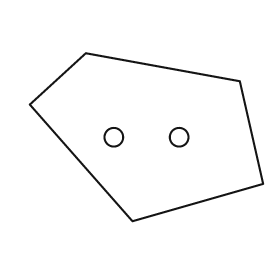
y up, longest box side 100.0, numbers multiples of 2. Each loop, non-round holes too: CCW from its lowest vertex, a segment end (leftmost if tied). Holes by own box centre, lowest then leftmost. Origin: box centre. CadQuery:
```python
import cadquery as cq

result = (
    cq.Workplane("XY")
    .moveTo(-6.0, -36.0)
    .lineTo(50.0, -20.0)
    .lineTo(40.0, 24.0)
    .lineTo(-26.0, 36.0)
    .lineTo(-50.0, 14.0)
    .close()
    .moveTo(-14.0, 0.0)
    .circle(4.0)
    .moveTo(14.0, 0.0)
    .circle(4.0)
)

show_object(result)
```